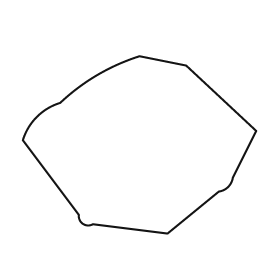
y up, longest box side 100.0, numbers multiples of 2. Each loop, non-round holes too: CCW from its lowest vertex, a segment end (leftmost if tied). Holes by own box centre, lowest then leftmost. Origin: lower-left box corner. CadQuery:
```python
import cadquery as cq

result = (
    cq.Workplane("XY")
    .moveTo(62.0, 0.0)
    .lineTo(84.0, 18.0)
    .threePointArc((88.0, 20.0), (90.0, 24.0))
    .lineTo(100.0, 44.0)
    .lineTo(70.0, 72.0)
    .lineTo(50.0, 76.0)
    .threePointArc((32.0, 68.0), (16.0, 56.0))
    .threePointArc((6.0, 50.0), (0.0, 40.0))
    .lineTo(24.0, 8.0)
    .threePointArc((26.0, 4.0), (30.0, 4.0))
    .close()
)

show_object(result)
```